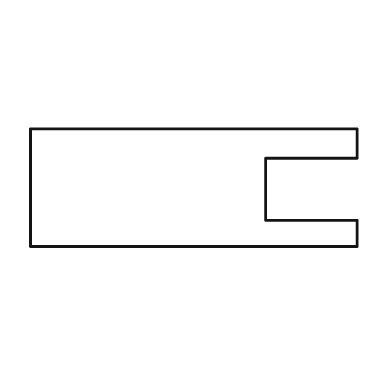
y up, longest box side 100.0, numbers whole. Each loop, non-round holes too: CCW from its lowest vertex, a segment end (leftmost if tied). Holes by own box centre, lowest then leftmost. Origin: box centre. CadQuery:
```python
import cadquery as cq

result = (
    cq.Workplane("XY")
    .moveTo(-50.0, -18.0)
    .lineTo(50.0, -18.0)
    .lineTo(50.0, -10.0)
    .lineTo(22.0, -10.0)
    .lineTo(22.0, 9.0)
    .lineTo(50.0, 9.0)
    .lineTo(50.0, 18.0)
    .lineTo(-50.0, 18.0)
    .close()
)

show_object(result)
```